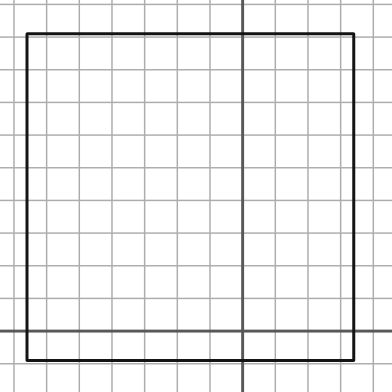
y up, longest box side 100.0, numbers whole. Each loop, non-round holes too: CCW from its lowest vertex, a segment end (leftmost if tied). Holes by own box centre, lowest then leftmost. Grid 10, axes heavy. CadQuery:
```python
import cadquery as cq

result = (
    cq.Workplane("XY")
    .moveTo(-66.0, -9.0)
    .lineTo(34.0, -9.0)
    .lineTo(34.0, 91.0)
    .lineTo(-66.0, 91.0)
    .close()
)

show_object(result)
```